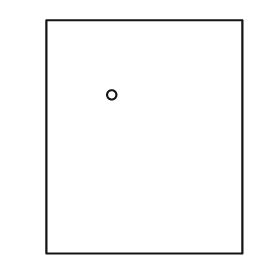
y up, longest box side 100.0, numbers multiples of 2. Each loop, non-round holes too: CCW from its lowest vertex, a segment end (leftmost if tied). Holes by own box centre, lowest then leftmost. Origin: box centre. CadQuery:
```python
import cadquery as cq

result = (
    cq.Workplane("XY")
    .moveTo(-42.0, -50.0)
    .lineTo(42.0, -50.0)
    .lineTo(42.0, 50.0)
    .lineTo(-42.0, 50.0)
    .close()
    .moveTo(-14.0, 18.0)
    .circle(2.0)
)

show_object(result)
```